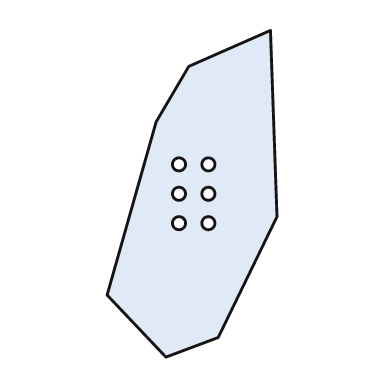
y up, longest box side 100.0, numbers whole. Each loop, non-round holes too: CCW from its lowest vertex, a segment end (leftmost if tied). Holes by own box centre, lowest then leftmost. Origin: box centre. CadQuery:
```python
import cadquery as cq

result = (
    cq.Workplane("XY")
    .moveTo(-8.0, -50.0)
    .lineTo(8.0, -44.0)
    .lineTo(26.0, -7.0)
    .lineTo(24.0, 50.0)
    .lineTo(-1.0, 39.0)
    .lineTo(-11.0, 22.0)
    .lineTo(-26.0, -31.0)
    .close()
    .moveTo(-4.0, -9.0)
    .circle(2.0)
    .moveTo(5.0, -9.0)
    .circle(2.0)
    .moveTo(-4.0, 0.0)
    .circle(2.0)
    .moveTo(5.0, 0.0)
    .circle(2.0)
    .moveTo(-4.0, 9.0)
    .circle(2.0)
    .moveTo(5.0, 9.0)
    .circle(2.0)
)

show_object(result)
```